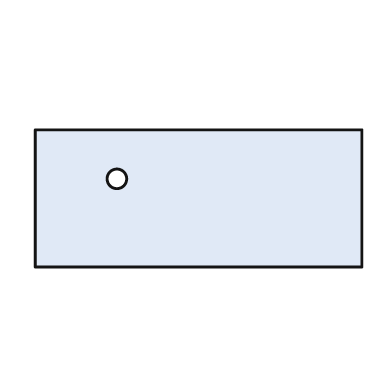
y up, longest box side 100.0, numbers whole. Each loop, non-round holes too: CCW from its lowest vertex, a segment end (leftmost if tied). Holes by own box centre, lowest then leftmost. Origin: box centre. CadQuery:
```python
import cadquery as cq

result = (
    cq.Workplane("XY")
    .moveTo(-50.0, -21.0)
    .lineTo(50.0, -21.0)
    .lineTo(50.0, 21.0)
    .lineTo(-50.0, 21.0)
    .close()
    .moveTo(-25.0, 6.0)
    .circle(3.0)
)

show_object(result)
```